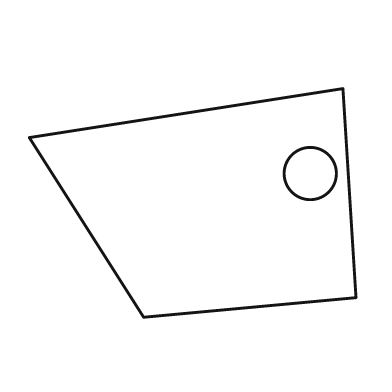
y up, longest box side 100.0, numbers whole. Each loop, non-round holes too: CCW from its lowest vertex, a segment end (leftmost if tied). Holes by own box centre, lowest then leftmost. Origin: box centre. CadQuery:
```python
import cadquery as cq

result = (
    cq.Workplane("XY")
    .moveTo(-15.0, -35.0)
    .lineTo(50.0, -29.0)
    .lineTo(46.0, 35.0)
    .lineTo(-50.0, 20.0)
    .close()
    .moveTo(36.0, 9.0)
    .circle(8.0)
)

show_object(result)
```